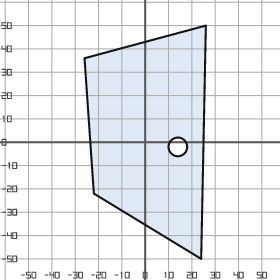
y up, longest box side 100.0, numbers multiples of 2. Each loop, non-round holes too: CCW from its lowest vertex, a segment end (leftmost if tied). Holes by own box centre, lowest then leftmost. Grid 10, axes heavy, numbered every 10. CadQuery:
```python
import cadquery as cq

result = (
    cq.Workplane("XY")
    .moveTo(24.0, -50.0)
    .lineTo(26.0, 50.0)
    .lineTo(-26.0, 36.0)
    .lineTo(-22.0, -22.0)
    .close()
    .moveTo(14.0, -2.0)
    .circle(4.0)
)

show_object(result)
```